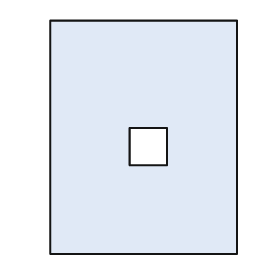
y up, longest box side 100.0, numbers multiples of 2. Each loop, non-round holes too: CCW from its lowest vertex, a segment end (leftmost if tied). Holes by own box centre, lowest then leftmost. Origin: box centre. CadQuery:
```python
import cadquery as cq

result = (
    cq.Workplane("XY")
    .moveTo(-40.0, -50.0)
    .lineTo(40.0, -50.0)
    .lineTo(40.0, 50.0)
    .lineTo(-40.0, 50.0)
    .close()
    .moveTo(-6.0, -12.0)
    .lineTo(10.0, -12.0)
    .lineTo(10.0, 4.0)
    .lineTo(-6.0, 4.0)
    .close()
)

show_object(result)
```